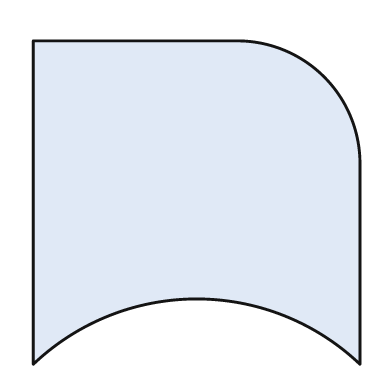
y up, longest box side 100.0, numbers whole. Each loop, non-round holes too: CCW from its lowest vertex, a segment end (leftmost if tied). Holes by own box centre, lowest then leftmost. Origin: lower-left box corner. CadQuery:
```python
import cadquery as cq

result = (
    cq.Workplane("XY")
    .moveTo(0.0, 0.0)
    .threePointArc((50.0, 20.0), (100.0, 0.0))
    .lineTo(100.0, 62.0)
    .threePointArc((89.0, 88.0), (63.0, 99.0))
    .lineTo(0.0, 99.0)
    .close()
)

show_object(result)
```